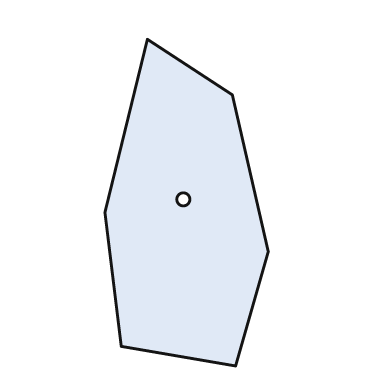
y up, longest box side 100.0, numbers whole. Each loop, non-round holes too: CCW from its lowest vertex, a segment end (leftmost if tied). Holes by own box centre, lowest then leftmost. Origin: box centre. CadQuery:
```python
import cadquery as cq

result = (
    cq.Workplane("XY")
    .moveTo(15.0, -50.0)
    .lineTo(25.0, -15.0)
    .lineTo(14.0, 33.0)
    .lineTo(-12.0, 50.0)
    .lineTo(-25.0, -3.0)
    .lineTo(-20.0, -44.0)
    .close()
    .moveTo(-1.0, 1.0)
    .circle(2.0)
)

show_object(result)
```